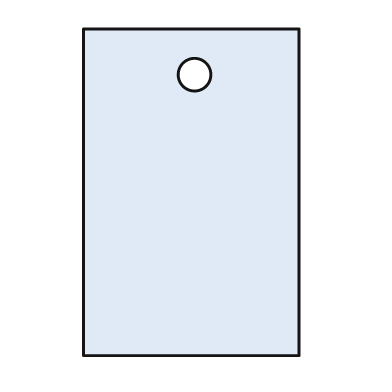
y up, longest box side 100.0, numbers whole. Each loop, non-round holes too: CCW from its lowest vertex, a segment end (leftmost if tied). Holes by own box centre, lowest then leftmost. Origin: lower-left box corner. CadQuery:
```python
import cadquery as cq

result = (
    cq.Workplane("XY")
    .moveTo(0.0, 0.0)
    .lineTo(66.0, 0.0)
    .lineTo(66.0, 100.0)
    .lineTo(0.0, 100.0)
    .close()
    .moveTo(34.0, 86.0)
    .circle(5.0)
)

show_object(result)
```